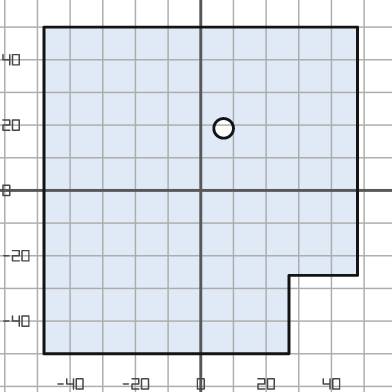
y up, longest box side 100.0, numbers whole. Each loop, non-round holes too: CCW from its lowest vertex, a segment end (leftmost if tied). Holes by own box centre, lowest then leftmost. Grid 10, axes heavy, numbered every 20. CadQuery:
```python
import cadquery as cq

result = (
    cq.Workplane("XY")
    .moveTo(-48.0, -50.0)
    .lineTo(27.0, -50.0)
    .lineTo(27.0, -26.0)
    .lineTo(48.0, -26.0)
    .lineTo(48.0, 50.0)
    .lineTo(-48.0, 50.0)
    .close()
    .moveTo(7.0, 19.0)
    .circle(3.0)
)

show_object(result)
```